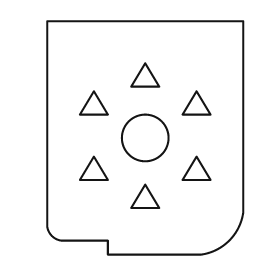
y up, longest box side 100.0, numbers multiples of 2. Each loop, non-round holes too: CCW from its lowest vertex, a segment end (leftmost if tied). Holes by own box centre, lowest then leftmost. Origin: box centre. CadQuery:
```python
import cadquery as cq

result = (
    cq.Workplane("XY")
    .moveTo(-16.0, -50.0)
    .lineTo(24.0, -50.0)
    .threePointArc((36.0, -44.0), (42.0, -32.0))
    .lineTo(42.0, 50.0)
    .lineTo(-42.0, 50.0)
    .lineTo(-42.0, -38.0)
    .threePointArc((-40.0, -42.0), (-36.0, -44.0))
    .lineTo(-16.0, -44.0)
    .close()
    .moveTo(-6.0, -30.0)
    .lineTo(6.0, -30.0)
    .lineTo(0.0, -20.0)
    .close()
    .moveTo(-28.0, -18.0)
    .lineTo(-16.0, -18.0)
    .lineTo(-22.0, -8.0)
    .close()
    .moveTo(16.0, -18.0)
    .lineTo(28.0, -18.0)
    .lineTo(22.0, -8.0)
    .close()
    .moveTo(0.0, 0.0)
    .circle(10.0)
    .moveTo(-28.0, 10.0)
    .lineTo(-16.0, 10.0)
    .lineTo(-22.0, 20.0)
    .close()
    .moveTo(16.0, 10.0)
    .lineTo(28.0, 10.0)
    .lineTo(22.0, 20.0)
    .close()
    .moveTo(-6.0, 22.0)
    .lineTo(6.0, 22.0)
    .lineTo(0.0, 32.0)
    .close()
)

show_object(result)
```